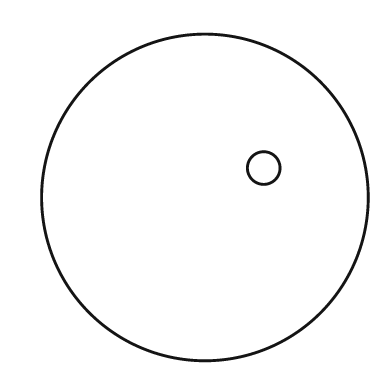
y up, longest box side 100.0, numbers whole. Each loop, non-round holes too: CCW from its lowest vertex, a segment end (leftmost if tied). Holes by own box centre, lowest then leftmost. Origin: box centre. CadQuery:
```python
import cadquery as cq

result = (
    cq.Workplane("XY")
    .moveTo(0.0, 0.0)
    .circle(50.0)
    .moveTo(18.0, 9.0)
    .circle(5.0)
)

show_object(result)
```